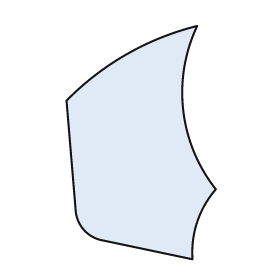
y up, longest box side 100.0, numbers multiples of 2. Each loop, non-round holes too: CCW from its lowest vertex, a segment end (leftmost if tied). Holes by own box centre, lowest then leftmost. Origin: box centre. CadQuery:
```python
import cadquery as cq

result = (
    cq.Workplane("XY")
    .moveTo(22.0, -50.0)
    .threePointArc((24.0, -34.0), (32.0, -20.0))
    .threePointArc((18.0, 14.0), (24.0, 50.0))
    .threePointArc((-6.0, 38.0), (-32.0, 18.0))
    .lineTo(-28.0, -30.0)
    .threePointArc((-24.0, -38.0), (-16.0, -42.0))
    .close()
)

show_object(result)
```